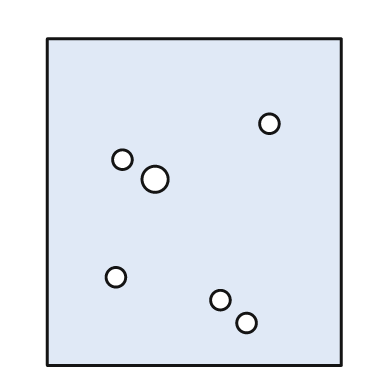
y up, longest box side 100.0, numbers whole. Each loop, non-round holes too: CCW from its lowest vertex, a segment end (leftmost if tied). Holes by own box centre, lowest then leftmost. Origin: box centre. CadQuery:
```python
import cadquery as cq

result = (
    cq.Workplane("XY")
    .moveTo(-45.0, -50.0)
    .lineTo(45.0, -50.0)
    .lineTo(45.0, 50.0)
    .lineTo(-45.0, 50.0)
    .close()
    .moveTo(16.0, -37.0)
    .circle(3.0)
    .moveTo(8.0, -30.0)
    .circle(3.0)
    .moveTo(-24.0, -23.0)
    .circle(3.0)
    .moveTo(-12.0, 7.0)
    .circle(4.0)
    .moveTo(-22.0, 13.0)
    .circle(3.0)
    .moveTo(23.0, 24.0)
    .circle(3.0)
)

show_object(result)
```